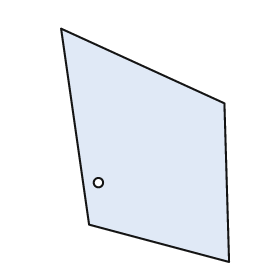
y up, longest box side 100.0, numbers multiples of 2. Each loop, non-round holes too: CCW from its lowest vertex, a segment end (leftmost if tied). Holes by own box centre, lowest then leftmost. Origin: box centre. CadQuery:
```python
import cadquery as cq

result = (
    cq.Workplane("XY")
    .moveTo(36.0, -50.0)
    .lineTo(34.0, 18.0)
    .lineTo(-36.0, 50.0)
    .lineTo(-24.0, -34.0)
    .close()
    .moveTo(-20.0, -16.0)
    .circle(2.0)
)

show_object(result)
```